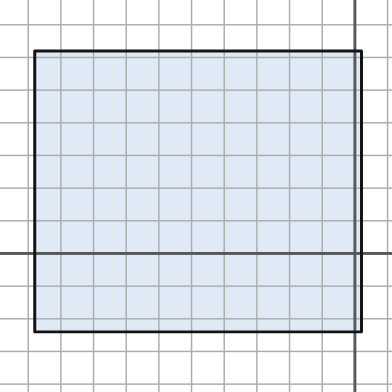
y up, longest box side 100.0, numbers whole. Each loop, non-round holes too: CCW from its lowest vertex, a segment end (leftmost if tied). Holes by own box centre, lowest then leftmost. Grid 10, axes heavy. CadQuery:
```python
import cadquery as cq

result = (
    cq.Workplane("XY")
    .moveTo(-98.0, -24.0)
    .lineTo(2.0, -24.0)
    .lineTo(2.0, 62.0)
    .lineTo(-98.0, 62.0)
    .close()
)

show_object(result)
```